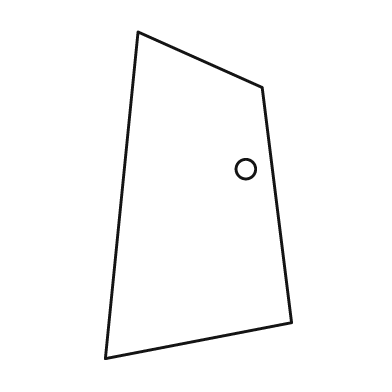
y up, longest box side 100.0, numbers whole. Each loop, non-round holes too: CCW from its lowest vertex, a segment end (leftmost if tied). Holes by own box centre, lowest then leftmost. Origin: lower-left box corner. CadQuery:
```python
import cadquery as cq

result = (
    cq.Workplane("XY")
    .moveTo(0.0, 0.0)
    .lineTo(57.0, 11.0)
    .lineTo(48.0, 83.0)
    .lineTo(10.0, 100.0)
    .close()
    .moveTo(43.0, 58.0)
    .circle(3.0)
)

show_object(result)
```